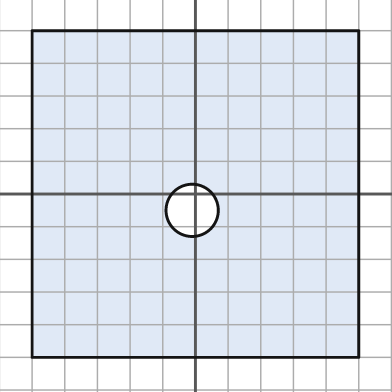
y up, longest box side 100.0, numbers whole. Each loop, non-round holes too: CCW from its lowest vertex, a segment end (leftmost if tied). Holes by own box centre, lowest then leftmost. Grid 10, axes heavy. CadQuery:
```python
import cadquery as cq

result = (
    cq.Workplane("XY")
    .moveTo(-50.0, -50.0)
    .lineTo(50.0, -50.0)
    .lineTo(50.0, 50.0)
    .lineTo(-50.0, 50.0)
    .close()
    .moveTo(-1.0, -5.0)
    .circle(8.0)
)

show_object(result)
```